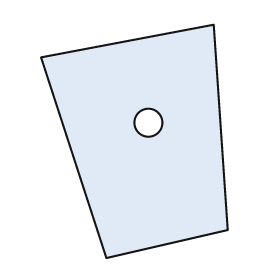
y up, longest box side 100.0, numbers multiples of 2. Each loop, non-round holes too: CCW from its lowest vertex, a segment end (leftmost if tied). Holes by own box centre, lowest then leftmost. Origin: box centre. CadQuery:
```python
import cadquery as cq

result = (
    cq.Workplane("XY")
    .moveTo(-12.0, -50.0)
    .lineTo(40.0, -38.0)
    .lineTo(34.0, 50.0)
    .lineTo(-40.0, 36.0)
    .close()
    .moveTo(6.0, 8.0)
    .circle(6.0)
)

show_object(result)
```